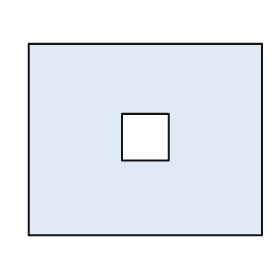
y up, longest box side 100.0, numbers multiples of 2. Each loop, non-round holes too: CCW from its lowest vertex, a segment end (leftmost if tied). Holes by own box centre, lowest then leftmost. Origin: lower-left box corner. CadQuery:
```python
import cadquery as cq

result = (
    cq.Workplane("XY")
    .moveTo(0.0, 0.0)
    .lineTo(100.0, 0.0)
    .lineTo(100.0, 82.0)
    .lineTo(0.0, 82.0)
    .close()
    .moveTo(40.0, 32.0)
    .lineTo(60.0, 32.0)
    .lineTo(60.0, 52.0)
    .lineTo(40.0, 52.0)
    .close()
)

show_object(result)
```